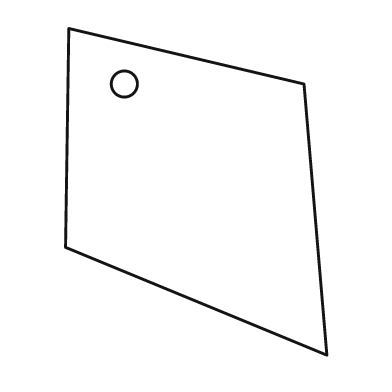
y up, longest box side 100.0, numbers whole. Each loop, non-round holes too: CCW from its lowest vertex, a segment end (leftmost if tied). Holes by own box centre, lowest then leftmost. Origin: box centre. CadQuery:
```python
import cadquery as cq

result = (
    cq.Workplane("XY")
    .moveTo(40.0, -50.0)
    .lineTo(33.0, 33.0)
    .lineTo(-39.0, 50.0)
    .lineTo(-40.0, -17.0)
    .close()
    .moveTo(-22.0, 33.0)
    .circle(4.0)
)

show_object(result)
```